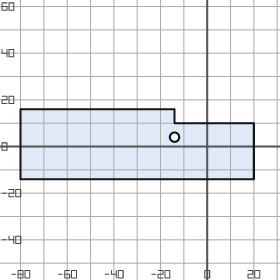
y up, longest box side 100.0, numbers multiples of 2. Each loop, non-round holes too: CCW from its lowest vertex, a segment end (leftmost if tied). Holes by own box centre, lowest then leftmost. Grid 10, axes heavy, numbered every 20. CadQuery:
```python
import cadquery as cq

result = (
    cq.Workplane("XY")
    .moveTo(-80.0, -14.0)
    .lineTo(20.0, -14.0)
    .lineTo(20.0, 10.0)
    .lineTo(-14.0, 10.0)
    .lineTo(-14.0, 16.0)
    .lineTo(-80.0, 16.0)
    .close()
    .moveTo(-14.0, 4.0)
    .circle(2.0)
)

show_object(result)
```